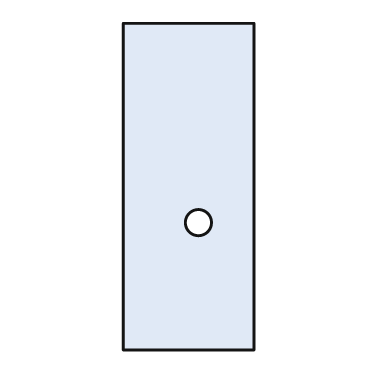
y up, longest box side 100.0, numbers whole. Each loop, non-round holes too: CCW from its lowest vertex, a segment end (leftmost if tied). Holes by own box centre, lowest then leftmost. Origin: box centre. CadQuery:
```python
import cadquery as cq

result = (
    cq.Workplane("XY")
    .moveTo(-20.0, -50.0)
    .lineTo(20.0, -50.0)
    .lineTo(20.0, 50.0)
    .lineTo(-20.0, 50.0)
    .close()
    .moveTo(3.0, -11.0)
    .circle(4.0)
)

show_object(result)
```